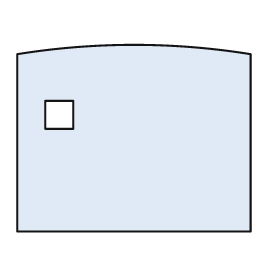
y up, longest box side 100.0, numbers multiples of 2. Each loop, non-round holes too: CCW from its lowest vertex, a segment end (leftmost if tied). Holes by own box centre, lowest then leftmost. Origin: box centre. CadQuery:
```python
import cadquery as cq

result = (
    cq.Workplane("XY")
    .moveTo(-50.0, -40.0)
    .lineTo(50.0, -40.0)
    .lineTo(50.0, 36.0)
    .threePointArc((0.0, 40.0), (-50.0, 36.0))
    .close()
    .moveTo(-38.0, 4.0)
    .lineTo(-26.0, 4.0)
    .lineTo(-26.0, 16.0)
    .lineTo(-38.0, 16.0)
    .close()
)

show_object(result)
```